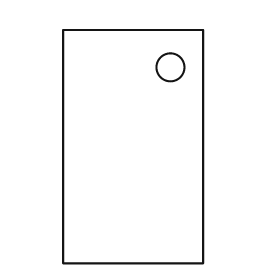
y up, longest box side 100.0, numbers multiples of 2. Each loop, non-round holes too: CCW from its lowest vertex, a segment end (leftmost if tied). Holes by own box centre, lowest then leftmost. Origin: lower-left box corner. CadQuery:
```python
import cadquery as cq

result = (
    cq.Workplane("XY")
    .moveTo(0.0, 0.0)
    .lineTo(60.0, 0.0)
    .lineTo(60.0, 100.0)
    .lineTo(0.0, 100.0)
    .close()
    .moveTo(46.0, 84.0)
    .circle(6.0)
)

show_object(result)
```